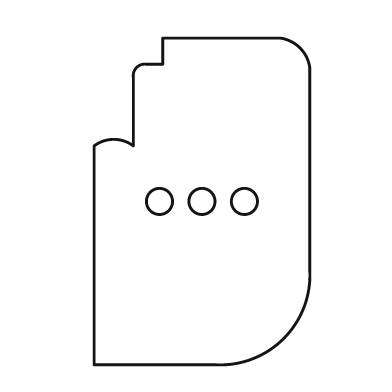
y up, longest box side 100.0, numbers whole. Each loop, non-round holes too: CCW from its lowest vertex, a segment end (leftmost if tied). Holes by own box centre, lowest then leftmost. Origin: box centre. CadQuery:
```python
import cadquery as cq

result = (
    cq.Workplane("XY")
    .moveTo(-33.0, -50.0)
    .lineTo(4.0, -50.0)
    .threePointArc((25.0, -42.0), (33.0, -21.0))
    .lineTo(33.0, 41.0)
    .threePointArc((30.0, 47.0), (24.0, 50.0))
    .lineTo(-12.0, 50.0)
    .lineTo(-12.0, 42.0)
    .lineTo(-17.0, 42.0)
    .threePointArc((-20.0, 41.0), (-21.0, 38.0))
    .lineTo(-21.0, 17.0)
    .threePointArc((-27.0, 19.0), (-33.0, 17.0))
    .close()
    .moveTo(-13.0, 0.0)
    .circle(4.0)
    .moveTo(0.0, 0.0)
    .circle(4.0)
    .moveTo(13.0, 0.0)
    .circle(4.0)
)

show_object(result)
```